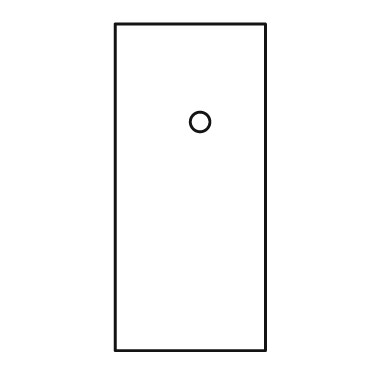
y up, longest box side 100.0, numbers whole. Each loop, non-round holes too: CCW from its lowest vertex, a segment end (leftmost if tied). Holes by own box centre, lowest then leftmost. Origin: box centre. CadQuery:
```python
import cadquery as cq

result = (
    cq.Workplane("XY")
    .moveTo(-23.0, -50.0)
    .lineTo(23.0, -50.0)
    .lineTo(23.0, 50.0)
    .lineTo(-23.0, 50.0)
    .close()
    .moveTo(3.0, 20.0)
    .circle(3.0)
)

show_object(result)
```